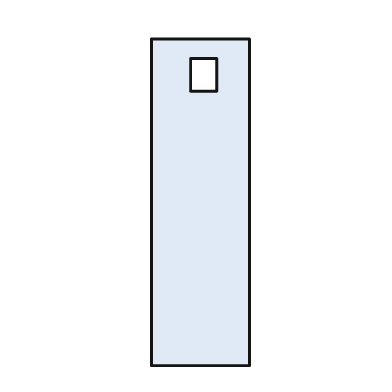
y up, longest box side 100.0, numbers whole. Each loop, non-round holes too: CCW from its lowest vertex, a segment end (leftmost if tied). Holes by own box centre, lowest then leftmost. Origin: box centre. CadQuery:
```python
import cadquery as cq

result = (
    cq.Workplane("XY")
    .moveTo(-15.0, -50.0)
    .lineTo(15.0, -50.0)
    .lineTo(15.0, 50.0)
    .lineTo(-15.0, 50.0)
    .close()
    .moveTo(-3.0, 34.0)
    .lineTo(5.0, 34.0)
    .lineTo(5.0, 44.0)
    .lineTo(-3.0, 44.0)
    .close()
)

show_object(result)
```